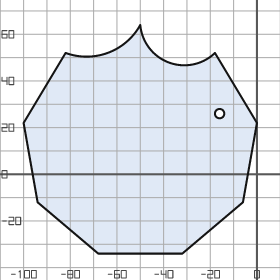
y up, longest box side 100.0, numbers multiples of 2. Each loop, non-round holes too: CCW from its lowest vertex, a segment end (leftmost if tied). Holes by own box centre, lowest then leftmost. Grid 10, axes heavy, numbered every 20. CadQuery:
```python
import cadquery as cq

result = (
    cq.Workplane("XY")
    .moveTo(-68.0, -34.0)
    .lineTo(-32.0, -34.0)
    .lineTo(-6.0, -12.0)
    .lineTo(0.0, 22.0)
    .lineTo(-18.0, 52.0)
    .threePointArc((-38.0, 48.0), (-50.0, 64.0))
    .threePointArc((-64.0, 52.0), (-82.0, 52.0))
    .lineTo(-100.0, 22.0)
    .lineTo(-94.0, -12.0)
    .close()
    .moveTo(-16.0, 26.0)
    .circle(2.0)
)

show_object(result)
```